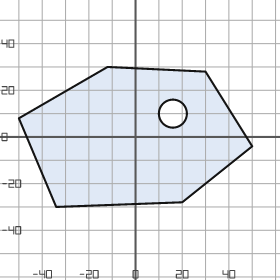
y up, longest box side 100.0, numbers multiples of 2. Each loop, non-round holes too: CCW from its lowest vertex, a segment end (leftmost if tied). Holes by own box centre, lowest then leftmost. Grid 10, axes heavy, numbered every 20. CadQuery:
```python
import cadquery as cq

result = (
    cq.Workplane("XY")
    .moveTo(-34.0, -30.0)
    .lineTo(20.0, -28.0)
    .lineTo(50.0, -4.0)
    .lineTo(30.0, 28.0)
    .lineTo(-12.0, 30.0)
    .lineTo(-50.0, 8.0)
    .close()
    .moveTo(16.0, 10.0)
    .circle(6.0)
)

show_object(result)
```